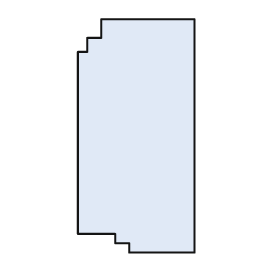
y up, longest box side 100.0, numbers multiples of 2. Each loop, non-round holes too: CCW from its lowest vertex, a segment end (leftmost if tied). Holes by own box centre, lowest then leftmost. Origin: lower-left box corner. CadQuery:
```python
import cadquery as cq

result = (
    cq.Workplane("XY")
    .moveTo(22.0, 0.0)
    .lineTo(50.0, 0.0)
    .lineTo(50.0, 100.0)
    .lineTo(10.0, 100.0)
    .lineTo(10.0, 92.0)
    .lineTo(4.0, 92.0)
    .lineTo(4.0, 86.0)
    .lineTo(0.0, 86.0)
    .lineTo(0.0, 8.0)
    .lineTo(16.0, 8.0)
    .lineTo(16.0, 4.0)
    .lineTo(22.0, 4.0)
    .close()
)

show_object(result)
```